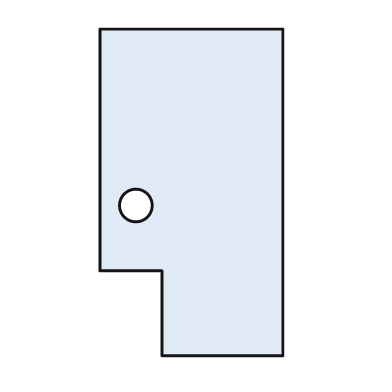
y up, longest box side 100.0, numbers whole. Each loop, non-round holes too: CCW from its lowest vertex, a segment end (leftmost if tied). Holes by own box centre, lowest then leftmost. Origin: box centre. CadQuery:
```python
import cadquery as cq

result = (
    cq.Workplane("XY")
    .moveTo(-9.0, -50.0)
    .lineTo(28.0, -50.0)
    .lineTo(28.0, 50.0)
    .lineTo(-28.0, 50.0)
    .lineTo(-28.0, -24.0)
    .lineTo(-9.0, -24.0)
    .close()
    .moveTo(-17.0, -4.0)
    .circle(5.0)
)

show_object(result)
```